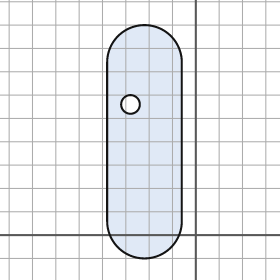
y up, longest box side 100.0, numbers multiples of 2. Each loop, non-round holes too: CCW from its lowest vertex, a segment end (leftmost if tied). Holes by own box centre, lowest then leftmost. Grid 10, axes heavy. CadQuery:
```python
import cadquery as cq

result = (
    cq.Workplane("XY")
    .moveTo(-38.0, 6.0)
    .threePointArc((-22.0, -10.0), (-6.0, 6.0))
    .lineTo(-6.0, 74.0)
    .threePointArc((-22.0, 90.0), (-38.0, 74.0))
    .close()
    .moveTo(-28.0, 56.0)
    .circle(4.0)
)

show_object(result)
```